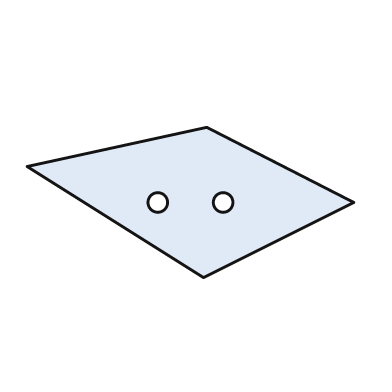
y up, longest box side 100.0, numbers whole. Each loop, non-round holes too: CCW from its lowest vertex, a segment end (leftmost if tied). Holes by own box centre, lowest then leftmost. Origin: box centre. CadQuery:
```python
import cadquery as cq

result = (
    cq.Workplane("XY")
    .moveTo(4.0, -23.0)
    .lineTo(50.0, 0.0)
    .lineTo(5.0, 23.0)
    .lineTo(-50.0, 11.0)
    .close()
    .moveTo(-10.0, 0.0)
    .circle(3.0)
    .moveTo(10.0, 0.0)
    .circle(3.0)
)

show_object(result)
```